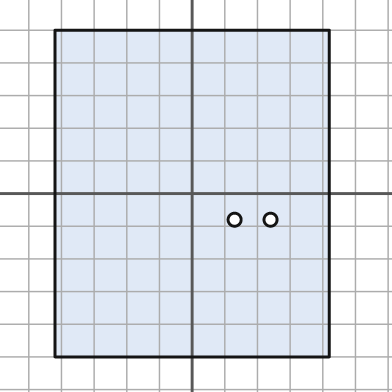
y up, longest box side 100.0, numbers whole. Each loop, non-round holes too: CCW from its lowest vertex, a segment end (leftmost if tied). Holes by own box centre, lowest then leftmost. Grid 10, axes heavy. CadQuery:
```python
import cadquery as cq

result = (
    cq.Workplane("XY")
    .moveTo(-42.0, -50.0)
    .lineTo(42.0, -50.0)
    .lineTo(42.0, 50.0)
    .lineTo(-42.0, 50.0)
    .close()
    .moveTo(13.0, -8.0)
    .circle(2.0)
    .moveTo(24.0, -8.0)
    .circle(2.0)
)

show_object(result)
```